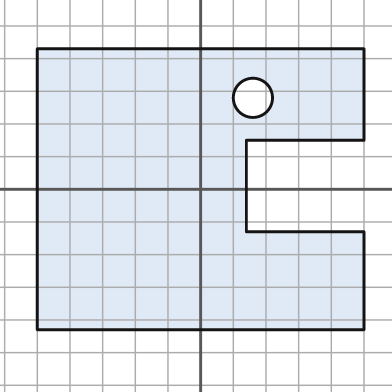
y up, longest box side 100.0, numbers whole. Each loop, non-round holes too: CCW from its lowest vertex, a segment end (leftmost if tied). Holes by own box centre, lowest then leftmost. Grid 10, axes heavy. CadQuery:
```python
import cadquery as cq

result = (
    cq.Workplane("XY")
    .moveTo(-50.0, -43.0)
    .lineTo(50.0, -43.0)
    .lineTo(50.0, -13.0)
    .lineTo(14.0, -13.0)
    .lineTo(14.0, 15.0)
    .lineTo(50.0, 15.0)
    .lineTo(50.0, 43.0)
    .lineTo(-50.0, 43.0)
    .close()
    .moveTo(16.0, 28.0)
    .circle(6.0)
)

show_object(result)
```